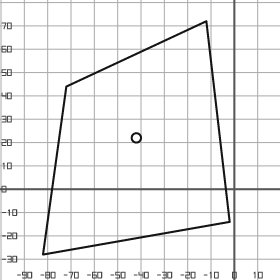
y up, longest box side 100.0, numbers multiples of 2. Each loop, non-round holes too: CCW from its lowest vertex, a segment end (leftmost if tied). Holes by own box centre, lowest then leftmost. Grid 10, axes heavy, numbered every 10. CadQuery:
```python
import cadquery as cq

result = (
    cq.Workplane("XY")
    .moveTo(-82.0, -28.0)
    .lineTo(-2.0, -14.0)
    .lineTo(-12.0, 72.0)
    .lineTo(-72.0, 44.0)
    .close()
    .moveTo(-42.0, 22.0)
    .circle(2.0)
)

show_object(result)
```